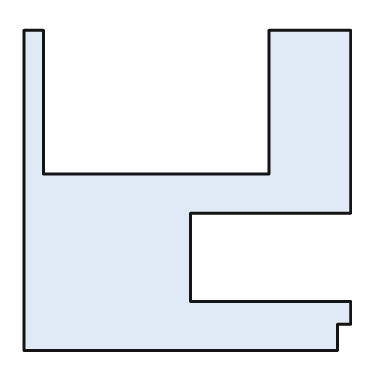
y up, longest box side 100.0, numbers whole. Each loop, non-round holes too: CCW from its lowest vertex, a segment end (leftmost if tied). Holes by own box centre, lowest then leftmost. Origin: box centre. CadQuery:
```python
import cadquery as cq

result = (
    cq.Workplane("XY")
    .moveTo(-50.0, -49.0)
    .lineTo(46.0, -49.0)
    .lineTo(46.0, -41.0)
    .lineTo(50.0, -41.0)
    .lineTo(50.0, -34.0)
    .lineTo(1.0, -34.0)
    .lineTo(1.0, -7.0)
    .lineTo(50.0, -7.0)
    .lineTo(50.0, 49.0)
    .lineTo(25.0, 49.0)
    .lineTo(25.0, 5.0)
    .lineTo(-44.0, 5.0)
    .lineTo(-44.0, 49.0)
    .lineTo(-50.0, 49.0)
    .close()
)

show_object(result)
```